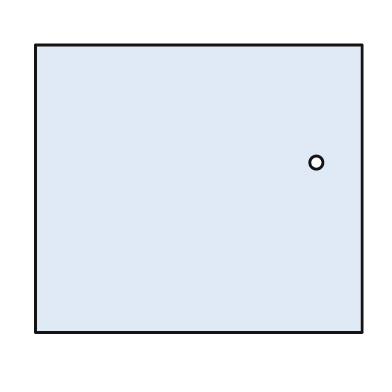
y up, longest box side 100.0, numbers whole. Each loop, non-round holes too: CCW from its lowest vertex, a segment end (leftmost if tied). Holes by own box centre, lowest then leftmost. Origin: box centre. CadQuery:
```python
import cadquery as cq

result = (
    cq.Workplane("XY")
    .moveTo(-50.0, -44.0)
    .lineTo(50.0, -44.0)
    .lineTo(50.0, 44.0)
    .lineTo(-50.0, 44.0)
    .close()
    .moveTo(36.0, 8.0)
    .circle(2.0)
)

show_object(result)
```